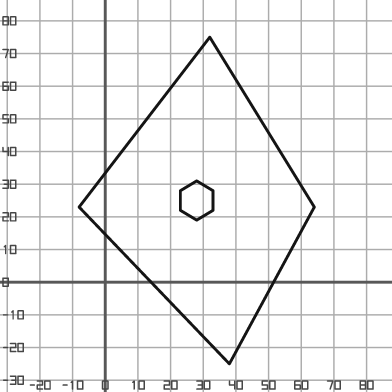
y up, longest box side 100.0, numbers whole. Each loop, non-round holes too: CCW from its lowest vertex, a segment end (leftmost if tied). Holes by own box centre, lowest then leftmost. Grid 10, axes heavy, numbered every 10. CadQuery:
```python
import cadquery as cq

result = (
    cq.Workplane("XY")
    .moveTo(38.0, -25.0)
    .lineTo(64.0, 23.0)
    .lineTo(32.0, 75.0)
    .lineTo(-8.0, 23.0)
    .close()
    .moveTo(28.0, 19.0)
    .lineTo(33.0, 22.0)
    .lineTo(33.0, 28.0)
    .lineTo(28.0, 31.0)
    .lineTo(23.0, 28.0)
    .lineTo(23.0, 22.0)
    .close()
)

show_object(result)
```